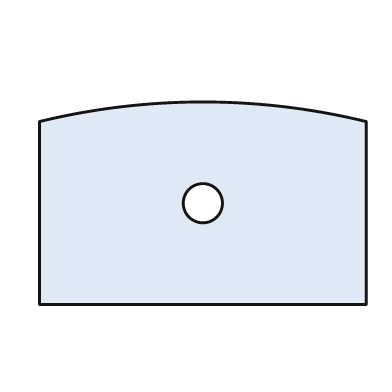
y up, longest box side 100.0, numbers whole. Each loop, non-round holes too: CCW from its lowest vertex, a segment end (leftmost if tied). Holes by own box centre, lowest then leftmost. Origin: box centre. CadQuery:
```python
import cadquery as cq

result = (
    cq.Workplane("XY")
    .moveTo(-50.0, -31.0)
    .lineTo(50.0, -31.0)
    .lineTo(50.0, 25.0)
    .threePointArc((0.0, 31.0), (-50.0, 25.0))
    .close()
    .moveTo(0.0, 0.0)
    .circle(6.0)
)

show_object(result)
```